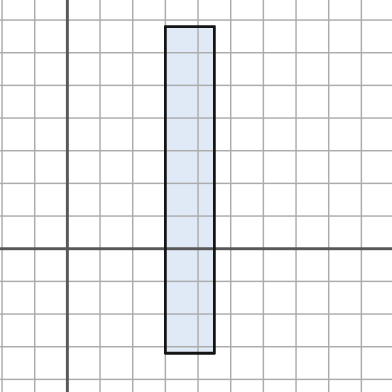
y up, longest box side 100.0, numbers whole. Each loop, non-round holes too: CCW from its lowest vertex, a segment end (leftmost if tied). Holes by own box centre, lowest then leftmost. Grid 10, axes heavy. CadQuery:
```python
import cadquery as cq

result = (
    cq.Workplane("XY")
    .moveTo(30.0, -32.0)
    .lineTo(45.0, -32.0)
    .lineTo(45.0, 68.0)
    .lineTo(30.0, 68.0)
    .close()
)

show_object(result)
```